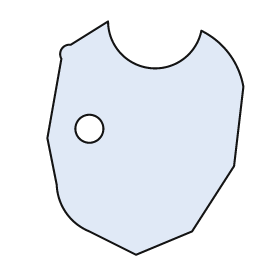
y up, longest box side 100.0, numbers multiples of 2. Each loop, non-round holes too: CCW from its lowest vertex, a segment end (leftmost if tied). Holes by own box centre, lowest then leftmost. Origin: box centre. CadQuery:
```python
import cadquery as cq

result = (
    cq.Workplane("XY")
    .moveTo(-4.0, -50.0)
    .lineTo(20.0, -40.0)
    .lineTo(38.0, -12.0)
    .lineTo(42.0, 22.0)
    .threePointArc((36.0, 36.0), (24.0, 46.0))
    .threePointArc((2.0, 30.0), (-16.0, 50.0))
    .lineTo(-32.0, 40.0)
    .threePointArc((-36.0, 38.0), (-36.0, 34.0))
    .lineTo(-42.0, 0.0)
    .lineTo(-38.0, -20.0)
    .threePointArc((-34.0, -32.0), (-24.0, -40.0))
    .close()
    .moveTo(-24.0, 4.0)
    .circle(6.0)
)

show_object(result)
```